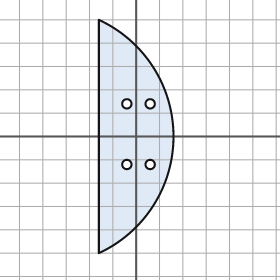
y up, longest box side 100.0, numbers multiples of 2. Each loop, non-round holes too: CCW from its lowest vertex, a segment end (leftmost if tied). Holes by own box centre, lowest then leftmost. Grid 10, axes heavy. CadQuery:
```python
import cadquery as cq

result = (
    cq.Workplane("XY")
    .moveTo(-16.0, -50.0)
    .threePointArc((16.0, 0.0), (-16.0, 50.0))
    .close()
    .moveTo(-4.0, -12.0)
    .circle(2.0)
    .moveTo(6.0, -12.0)
    .circle(2.0)
    .moveTo(-4.0, 14.0)
    .circle(2.0)
    .moveTo(6.0, 14.0)
    .circle(2.0)
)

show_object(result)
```